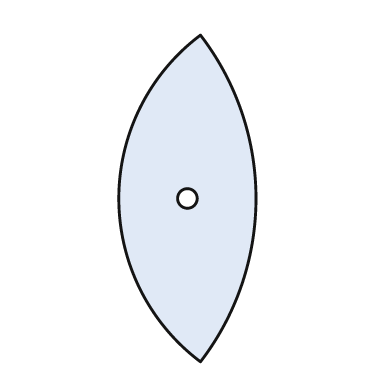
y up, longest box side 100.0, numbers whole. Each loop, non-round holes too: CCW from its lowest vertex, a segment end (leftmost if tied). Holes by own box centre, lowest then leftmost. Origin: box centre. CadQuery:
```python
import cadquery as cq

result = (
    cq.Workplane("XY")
    .moveTo(4.0, -50.0)
    .threePointArc((21.0, 0.0), (4.0, 50.0))
    .threePointArc((-21.0, 0.0), (4.0, -50.0))
    .close()
    .moveTo(0.0, 0.0)
    .circle(3.0)
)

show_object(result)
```